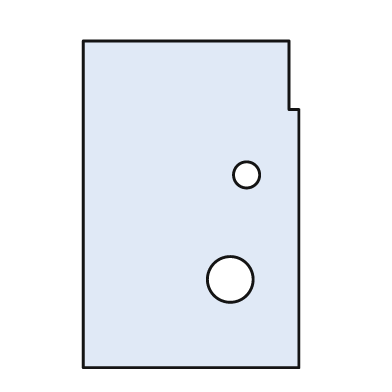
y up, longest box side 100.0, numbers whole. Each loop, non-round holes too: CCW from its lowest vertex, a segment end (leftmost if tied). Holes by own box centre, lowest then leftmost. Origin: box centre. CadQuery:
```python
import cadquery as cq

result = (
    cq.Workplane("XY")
    .moveTo(-33.0, -50.0)
    .lineTo(33.0, -50.0)
    .lineTo(33.0, 29.0)
    .lineTo(30.0, 29.0)
    .lineTo(30.0, 50.0)
    .lineTo(-33.0, 50.0)
    .close()
    .moveTo(12.0, -23.0)
    .circle(7.0)
    .moveTo(17.0, 9.0)
    .circle(4.0)
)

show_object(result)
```